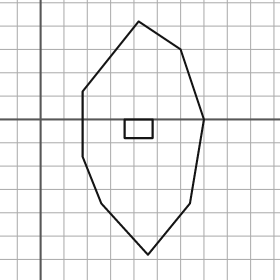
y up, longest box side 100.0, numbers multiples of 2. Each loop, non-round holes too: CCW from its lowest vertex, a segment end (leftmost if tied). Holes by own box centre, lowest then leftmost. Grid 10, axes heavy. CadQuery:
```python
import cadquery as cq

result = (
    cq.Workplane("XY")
    .moveTo(46.0, -58.0)
    .lineTo(64.0, -36.0)
    .lineTo(70.0, 0.0)
    .lineTo(60.0, 30.0)
    .lineTo(42.0, 42.0)
    .lineTo(18.0, 12.0)
    .lineTo(18.0, -16.0)
    .lineTo(26.0, -36.0)
    .close()
    .moveTo(36.0, -8.0)
    .lineTo(48.0, -8.0)
    .lineTo(48.0, 0.0)
    .lineTo(36.0, 0.0)
    .close()
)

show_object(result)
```